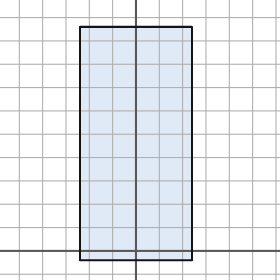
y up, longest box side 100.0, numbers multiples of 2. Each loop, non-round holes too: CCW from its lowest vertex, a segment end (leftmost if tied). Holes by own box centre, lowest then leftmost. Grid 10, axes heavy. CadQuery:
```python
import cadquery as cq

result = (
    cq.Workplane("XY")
    .moveTo(-24.0, -4.0)
    .lineTo(24.0, -4.0)
    .lineTo(24.0, 96.0)
    .lineTo(-24.0, 96.0)
    .close()
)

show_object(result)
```